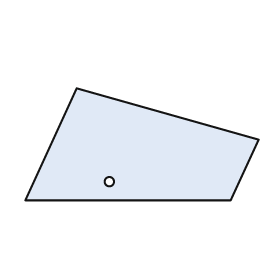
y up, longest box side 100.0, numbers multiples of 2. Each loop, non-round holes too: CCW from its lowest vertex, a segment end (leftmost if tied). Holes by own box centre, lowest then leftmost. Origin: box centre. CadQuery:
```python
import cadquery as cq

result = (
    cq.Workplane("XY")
    .moveTo(-50.0, -24.0)
    .lineTo(38.0, -24.0)
    .lineTo(50.0, 2.0)
    .lineTo(-28.0, 24.0)
    .close()
    .moveTo(-14.0, -16.0)
    .circle(2.0)
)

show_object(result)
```